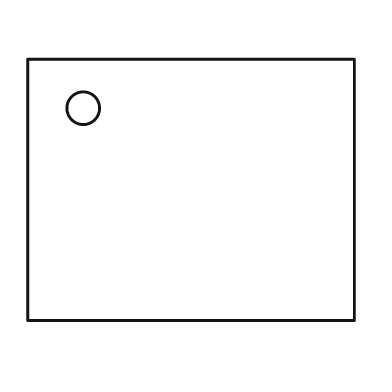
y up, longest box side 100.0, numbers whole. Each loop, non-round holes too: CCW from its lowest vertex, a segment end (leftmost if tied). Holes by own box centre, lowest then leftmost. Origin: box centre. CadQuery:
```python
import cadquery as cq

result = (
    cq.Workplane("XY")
    .moveTo(-50.0, -40.0)
    .lineTo(50.0, -40.0)
    .lineTo(50.0, 40.0)
    .lineTo(-50.0, 40.0)
    .close()
    .moveTo(-33.0, 25.0)
    .circle(5.0)
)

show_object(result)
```